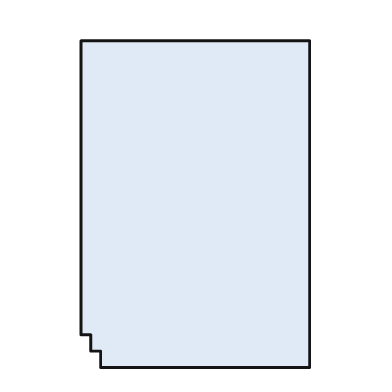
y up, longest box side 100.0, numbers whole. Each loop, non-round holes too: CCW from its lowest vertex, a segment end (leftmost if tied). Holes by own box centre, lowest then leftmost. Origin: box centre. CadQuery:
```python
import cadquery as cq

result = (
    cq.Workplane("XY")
    .moveTo(-29.0, -50.0)
    .lineTo(35.0, -50.0)
    .lineTo(35.0, 50.0)
    .lineTo(-35.0, 50.0)
    .lineTo(-35.0, -40.0)
    .lineTo(-32.0, -40.0)
    .lineTo(-32.0, -45.0)
    .lineTo(-29.0, -45.0)
    .close()
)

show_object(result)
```